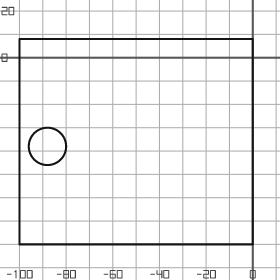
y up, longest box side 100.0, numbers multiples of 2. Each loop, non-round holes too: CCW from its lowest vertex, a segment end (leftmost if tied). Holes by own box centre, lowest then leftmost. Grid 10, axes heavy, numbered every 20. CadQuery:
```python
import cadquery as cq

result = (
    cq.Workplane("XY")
    .moveTo(-100.0, -80.0)
    .lineTo(0.0, -80.0)
    .lineTo(0.0, 8.0)
    .lineTo(-100.0, 8.0)
    .close()
    .moveTo(-88.0, -38.0)
    .circle(8.0)
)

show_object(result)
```